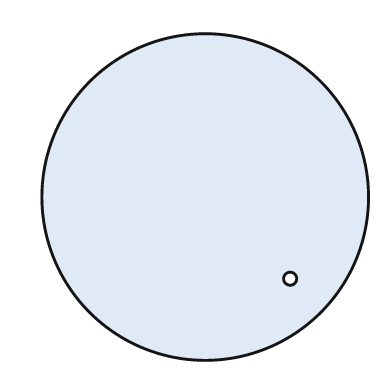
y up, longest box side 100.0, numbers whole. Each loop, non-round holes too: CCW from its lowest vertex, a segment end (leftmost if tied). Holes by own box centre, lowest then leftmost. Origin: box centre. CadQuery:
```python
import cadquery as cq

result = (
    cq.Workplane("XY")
    .moveTo(0.0, 0.0)
    .circle(50.0)
    .moveTo(26.0, -25.0)
    .circle(2.0)
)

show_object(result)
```